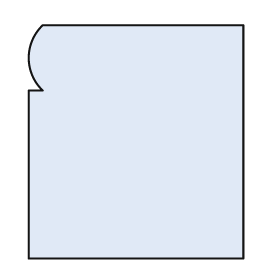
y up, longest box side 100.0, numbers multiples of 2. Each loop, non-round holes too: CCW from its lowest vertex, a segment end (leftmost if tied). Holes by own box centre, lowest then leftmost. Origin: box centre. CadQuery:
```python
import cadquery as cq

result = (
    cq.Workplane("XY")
    .moveTo(-46.0, -50.0)
    .lineTo(46.0, -50.0)
    .lineTo(46.0, 50.0)
    .lineTo(-40.0, 50.0)
    .threePointArc((-46.0, 36.0), (-40.0, 22.0))
    .lineTo(-46.0, 22.0)
    .close()
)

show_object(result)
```